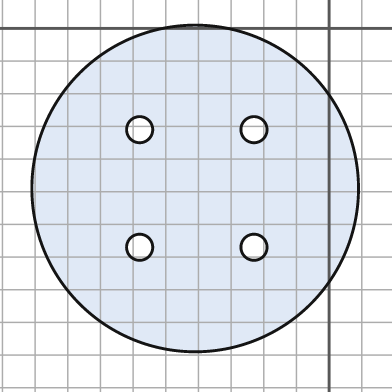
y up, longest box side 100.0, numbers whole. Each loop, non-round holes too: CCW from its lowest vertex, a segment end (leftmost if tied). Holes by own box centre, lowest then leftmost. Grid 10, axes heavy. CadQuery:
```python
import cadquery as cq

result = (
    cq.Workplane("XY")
    .moveTo(-41.0, -49.0)
    .circle(50.0)
    .moveTo(-58.0, -67.0)
    .circle(4.0)
    .moveTo(-23.0, -67.0)
    .circle(4.0)
    .moveTo(-58.0, -31.0)
    .circle(4.0)
    .moveTo(-23.0, -31.0)
    .circle(4.0)
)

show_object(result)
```